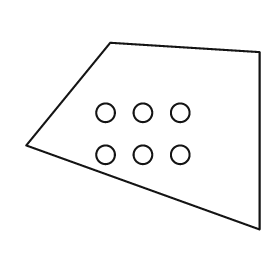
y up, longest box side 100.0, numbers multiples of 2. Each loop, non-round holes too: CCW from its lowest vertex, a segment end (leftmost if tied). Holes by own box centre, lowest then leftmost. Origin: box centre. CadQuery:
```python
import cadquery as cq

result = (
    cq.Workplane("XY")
    .moveTo(50.0, -40.0)
    .lineTo(50.0, 36.0)
    .lineTo(-14.0, 40.0)
    .lineTo(-50.0, -4.0)
    .close()
    .moveTo(-16.0, -8.0)
    .circle(4.0)
    .moveTo(0.0, -8.0)
    .circle(4.0)
    .moveTo(16.0, -8.0)
    .circle(4.0)
    .moveTo(-16.0, 10.0)
    .circle(4.0)
    .moveTo(0.0, 10.0)
    .circle(4.0)
    .moveTo(16.0, 10.0)
    .circle(4.0)
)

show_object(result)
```